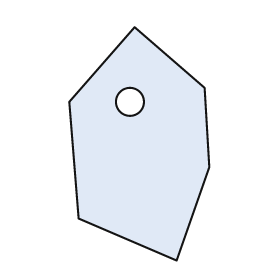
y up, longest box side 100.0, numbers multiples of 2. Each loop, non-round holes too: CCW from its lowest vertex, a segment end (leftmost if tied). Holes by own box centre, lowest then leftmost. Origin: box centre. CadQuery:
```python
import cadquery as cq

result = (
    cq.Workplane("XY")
    .moveTo(16.0, -50.0)
    .lineTo(30.0, -10.0)
    .lineTo(28.0, 24.0)
    .lineTo(-2.0, 50.0)
    .lineTo(-30.0, 18.0)
    .lineTo(-26.0, -32.0)
    .close()
    .moveTo(-4.0, 18.0)
    .circle(6.0)
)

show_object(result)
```